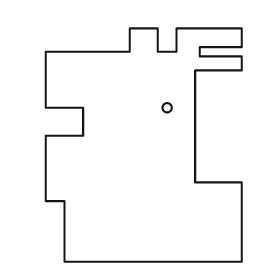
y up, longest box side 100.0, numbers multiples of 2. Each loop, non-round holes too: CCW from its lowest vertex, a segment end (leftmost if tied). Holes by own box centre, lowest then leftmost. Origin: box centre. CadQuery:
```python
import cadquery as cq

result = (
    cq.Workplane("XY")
    .moveTo(-34.0, -50.0)
    .lineTo(42.0, -50.0)
    .lineTo(42.0, -16.0)
    .lineTo(22.0, -16.0)
    .lineTo(22.0, 32.0)
    .lineTo(42.0, 32.0)
    .lineTo(42.0, 38.0)
    .lineTo(24.0, 38.0)
    .lineTo(24.0, 42.0)
    .lineTo(42.0, 42.0)
    .lineTo(42.0, 50.0)
    .lineTo(14.0, 50.0)
    .lineTo(14.0, 40.0)
    .lineTo(6.0, 40.0)
    .lineTo(6.0, 50.0)
    .lineTo(-6.0, 50.0)
    .lineTo(-6.0, 40.0)
    .lineTo(-42.0, 40.0)
    .lineTo(-42.0, 16.0)
    .lineTo(-26.0, 16.0)
    .lineTo(-26.0, 4.0)
    .lineTo(-42.0, 4.0)
    .lineTo(-42.0, -24.0)
    .lineTo(-34.0, -24.0)
    .close()
    .moveTo(10.0, 16.0)
    .circle(2.0)
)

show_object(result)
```